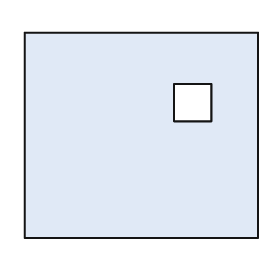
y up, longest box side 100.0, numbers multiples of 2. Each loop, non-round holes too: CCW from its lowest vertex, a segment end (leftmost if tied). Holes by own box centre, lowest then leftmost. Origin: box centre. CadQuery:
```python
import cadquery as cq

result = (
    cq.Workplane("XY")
    .moveTo(-50.0, -44.0)
    .lineTo(50.0, -44.0)
    .lineTo(50.0, 44.0)
    .lineTo(-50.0, 44.0)
    .close()
    .moveTo(14.0, 6.0)
    .lineTo(30.0, 6.0)
    .lineTo(30.0, 22.0)
    .lineTo(14.0, 22.0)
    .close()
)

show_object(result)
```